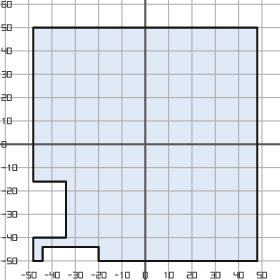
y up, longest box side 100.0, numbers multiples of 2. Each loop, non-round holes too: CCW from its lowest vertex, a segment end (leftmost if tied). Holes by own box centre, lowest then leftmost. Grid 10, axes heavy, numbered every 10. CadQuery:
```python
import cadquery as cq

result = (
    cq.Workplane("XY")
    .moveTo(-48.0, -50.0)
    .lineTo(-44.0, -50.0)
    .lineTo(-44.0, -44.0)
    .lineTo(-20.0, -44.0)
    .lineTo(-20.0, -50.0)
    .lineTo(48.0, -50.0)
    .lineTo(48.0, 50.0)
    .lineTo(-48.0, 50.0)
    .lineTo(-48.0, -16.0)
    .lineTo(-34.0, -16.0)
    .lineTo(-34.0, -40.0)
    .lineTo(-48.0, -40.0)
    .close()
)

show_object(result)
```